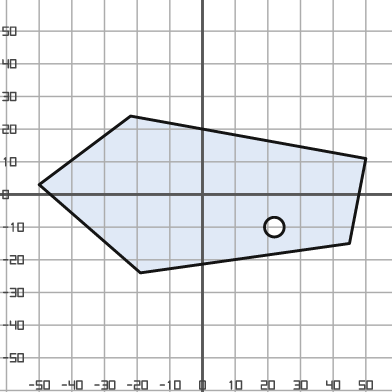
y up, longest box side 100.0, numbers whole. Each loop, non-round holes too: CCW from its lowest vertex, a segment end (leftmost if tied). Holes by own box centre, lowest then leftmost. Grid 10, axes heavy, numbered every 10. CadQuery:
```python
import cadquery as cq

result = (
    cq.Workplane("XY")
    .moveTo(-19.0, -24.0)
    .lineTo(45.0, -15.0)
    .lineTo(50.0, 11.0)
    .lineTo(-22.0, 24.0)
    .lineTo(-50.0, 3.0)
    .close()
    .moveTo(22.0, -10.0)
    .circle(3.0)
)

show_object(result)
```